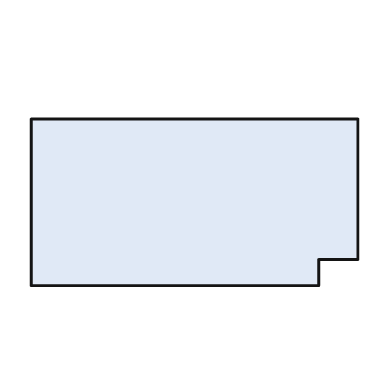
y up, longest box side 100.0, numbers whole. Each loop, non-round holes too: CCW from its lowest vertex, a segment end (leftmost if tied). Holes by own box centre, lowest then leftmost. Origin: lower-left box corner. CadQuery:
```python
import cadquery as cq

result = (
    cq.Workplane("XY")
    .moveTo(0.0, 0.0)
    .lineTo(88.0, 0.0)
    .lineTo(88.0, 8.0)
    .lineTo(100.0, 8.0)
    .lineTo(100.0, 51.0)
    .lineTo(0.0, 51.0)
    .close()
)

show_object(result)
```